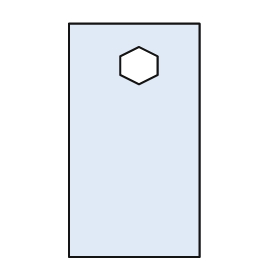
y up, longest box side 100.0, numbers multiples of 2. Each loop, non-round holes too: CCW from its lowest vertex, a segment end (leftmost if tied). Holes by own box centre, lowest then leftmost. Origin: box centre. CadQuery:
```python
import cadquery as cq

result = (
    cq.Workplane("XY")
    .moveTo(-28.0, -50.0)
    .lineTo(28.0, -50.0)
    .lineTo(28.0, 50.0)
    .lineTo(-28.0, 50.0)
    .close()
    .moveTo(2.0, 24.0)
    .lineTo(10.0, 28.0)
    .lineTo(10.0, 36.0)
    .lineTo(2.0, 40.0)
    .lineTo(-6.0, 36.0)
    .lineTo(-6.0, 28.0)
    .close()
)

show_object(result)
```